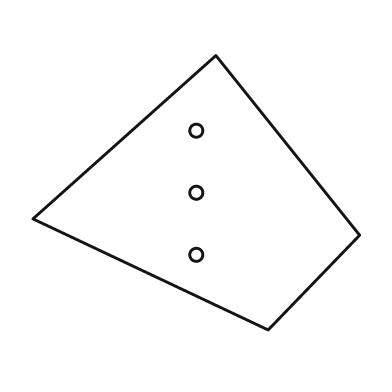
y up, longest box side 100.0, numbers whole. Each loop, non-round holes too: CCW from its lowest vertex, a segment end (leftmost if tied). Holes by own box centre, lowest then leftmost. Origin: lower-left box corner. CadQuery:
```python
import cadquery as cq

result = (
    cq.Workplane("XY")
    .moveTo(72.0, 0.0)
    .lineTo(100.0, 29.0)
    .lineTo(56.0, 84.0)
    .lineTo(0.0, 34.0)
    .close()
    .moveTo(50.0, 23.0)
    .circle(2.0)
    .moveTo(50.0, 42.0)
    .circle(2.0)
    .moveTo(50.0, 61.0)
    .circle(2.0)
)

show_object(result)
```